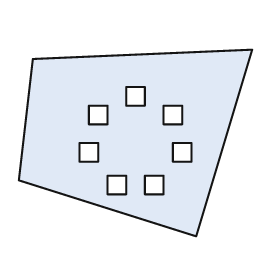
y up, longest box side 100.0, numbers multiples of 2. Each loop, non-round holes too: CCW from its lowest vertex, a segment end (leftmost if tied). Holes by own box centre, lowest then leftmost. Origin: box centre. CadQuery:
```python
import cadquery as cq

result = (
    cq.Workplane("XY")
    .moveTo(26.0, -40.0)
    .lineTo(50.0, 40.0)
    .lineTo(-44.0, 36.0)
    .lineTo(-50.0, -16.0)
    .close()
    .moveTo(-12.0, -22.0)
    .lineTo(-4.0, -22.0)
    .lineTo(-4.0, -14.0)
    .lineTo(-12.0, -14.0)
    .close()
    .moveTo(4.0, -22.0)
    .lineTo(12.0, -22.0)
    .lineTo(12.0, -14.0)
    .lineTo(4.0, -14.0)
    .close()
    .moveTo(-24.0, -8.0)
    .lineTo(-16.0, -8.0)
    .lineTo(-16.0, 0.0)
    .lineTo(-24.0, 0.0)
    .close()
    .moveTo(16.0, -8.0)
    .lineTo(24.0, -8.0)
    .lineTo(24.0, 0.0)
    .lineTo(16.0, 0.0)
    .close()
    .moveTo(-20.0, 8.0)
    .lineTo(-12.0, 8.0)
    .lineTo(-12.0, 16.0)
    .lineTo(-20.0, 16.0)
    .close()
    .moveTo(12.0, 8.0)
    .lineTo(20.0, 8.0)
    .lineTo(20.0, 16.0)
    .lineTo(12.0, 16.0)
    .close()
    .moveTo(-4.0, 16.0)
    .lineTo(4.0, 16.0)
    .lineTo(4.0, 24.0)
    .lineTo(-4.0, 24.0)
    .close()
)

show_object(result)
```